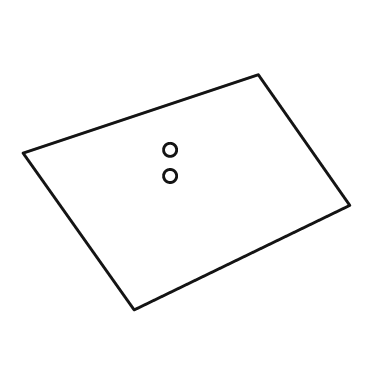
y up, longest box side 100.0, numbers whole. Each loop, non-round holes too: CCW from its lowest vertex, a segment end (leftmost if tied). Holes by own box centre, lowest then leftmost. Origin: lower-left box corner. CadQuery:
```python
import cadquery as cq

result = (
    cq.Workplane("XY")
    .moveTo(34.0, 0.0)
    .lineTo(100.0, 32.0)
    .lineTo(72.0, 72.0)
    .lineTo(0.0, 48.0)
    .close()
    .moveTo(45.0, 41.0)
    .circle(2.0)
    .moveTo(45.0, 49.0)
    .circle(2.0)
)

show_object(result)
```